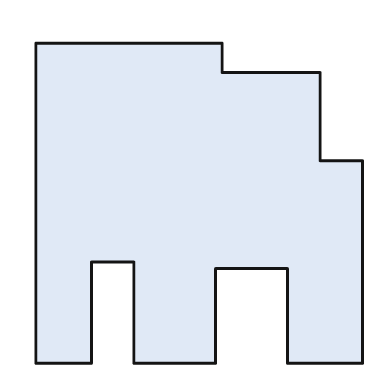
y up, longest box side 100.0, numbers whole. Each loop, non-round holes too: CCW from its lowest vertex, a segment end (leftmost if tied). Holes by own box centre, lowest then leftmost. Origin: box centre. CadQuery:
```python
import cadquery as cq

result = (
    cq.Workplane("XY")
    .moveTo(-50.0, -49.0)
    .lineTo(-33.0, -49.0)
    .lineTo(-33.0, -18.0)
    .lineTo(-20.0, -18.0)
    .lineTo(-20.0, -49.0)
    .lineTo(5.0, -49.0)
    .lineTo(5.0, -20.0)
    .lineTo(27.0, -20.0)
    .lineTo(27.0, -49.0)
    .lineTo(50.0, -49.0)
    .lineTo(50.0, 13.0)
    .lineTo(37.0, 13.0)
    .lineTo(37.0, 40.0)
    .lineTo(7.0, 40.0)
    .lineTo(7.0, 49.0)
    .lineTo(-50.0, 49.0)
    .close()
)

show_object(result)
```